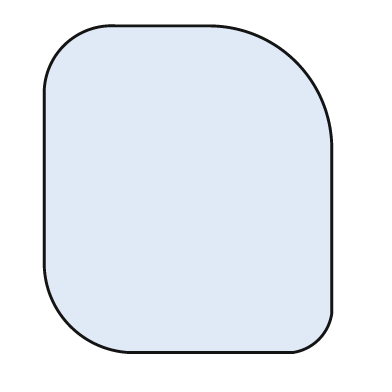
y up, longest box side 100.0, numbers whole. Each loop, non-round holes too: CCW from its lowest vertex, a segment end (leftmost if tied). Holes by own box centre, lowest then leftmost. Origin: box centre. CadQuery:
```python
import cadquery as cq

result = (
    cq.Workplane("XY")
    .moveTo(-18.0, -50.0)
    .lineTo(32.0, -50.0)
    .threePointArc((40.0, -46.0), (44.0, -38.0))
    .lineTo(44.0, 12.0)
    .threePointArc((33.0, 39.0), (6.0, 50.0))
    .lineTo(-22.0, 50.0)
    .threePointArc((-38.0, 44.0), (-44.0, 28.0))
    .lineTo(-44.0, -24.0)
    .threePointArc((-36.0, -42.0), (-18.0, -50.0))
    .close()
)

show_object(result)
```